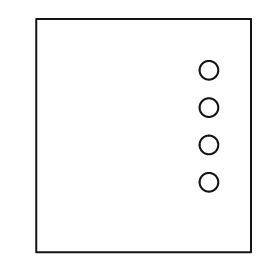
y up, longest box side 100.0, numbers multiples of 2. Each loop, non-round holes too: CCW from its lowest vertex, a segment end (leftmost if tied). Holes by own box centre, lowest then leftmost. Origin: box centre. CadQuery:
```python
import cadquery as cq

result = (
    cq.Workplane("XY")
    .moveTo(-46.0, -50.0)
    .lineTo(46.0, -50.0)
    .lineTo(46.0, 50.0)
    .lineTo(-46.0, 50.0)
    .close()
    .moveTo(28.0, -20.0)
    .circle(4.0)
    .moveTo(28.0, -4.0)
    .circle(4.0)
    .moveTo(28.0, 12.0)
    .circle(4.0)
    .moveTo(28.0, 28.0)
    .circle(4.0)
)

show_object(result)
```